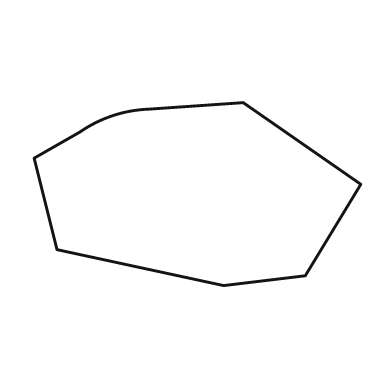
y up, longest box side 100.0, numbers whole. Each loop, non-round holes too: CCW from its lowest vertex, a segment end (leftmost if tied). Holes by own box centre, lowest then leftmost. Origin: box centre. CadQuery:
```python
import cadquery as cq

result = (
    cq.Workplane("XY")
    .moveTo(8.0, -28.0)
    .lineTo(33.0, -25.0)
    .lineTo(50.0, 3.0)
    .lineTo(14.0, 28.0)
    .lineTo(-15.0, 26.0)
    .threePointArc((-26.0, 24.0), (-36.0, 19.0))
    .lineTo(-50.0, 11.0)
    .lineTo(-43.0, -17.0)
    .close()
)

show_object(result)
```